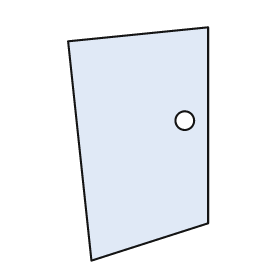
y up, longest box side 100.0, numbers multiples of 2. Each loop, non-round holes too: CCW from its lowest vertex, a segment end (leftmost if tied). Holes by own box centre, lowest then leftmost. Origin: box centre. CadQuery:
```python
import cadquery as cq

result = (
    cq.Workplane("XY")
    .moveTo(-20.0, -50.0)
    .lineTo(30.0, -34.0)
    .lineTo(30.0, 50.0)
    .lineTo(-30.0, 44.0)
    .close()
    .moveTo(20.0, 10.0)
    .circle(4.0)
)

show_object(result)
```